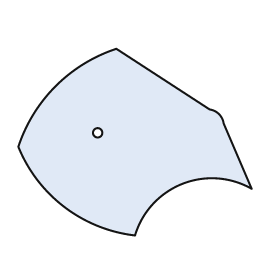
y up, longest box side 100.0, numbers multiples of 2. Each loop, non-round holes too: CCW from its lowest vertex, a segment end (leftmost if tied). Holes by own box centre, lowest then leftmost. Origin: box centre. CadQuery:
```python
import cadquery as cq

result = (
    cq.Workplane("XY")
    .moveTo(0.0, -40.0)
    .threePointArc((20.0, -18.0), (50.0, -20.0))
    .lineTo(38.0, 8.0)
    .threePointArc((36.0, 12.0), (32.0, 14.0))
    .lineTo(-8.0, 40.0)
    .threePointArc((-34.0, 24.0), (-50.0, -2.0))
    .threePointArc((-30.0, -28.0), (0.0, -40.0))
    .close()
    .moveTo(-16.0, 4.0)
    .circle(2.0)
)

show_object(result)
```